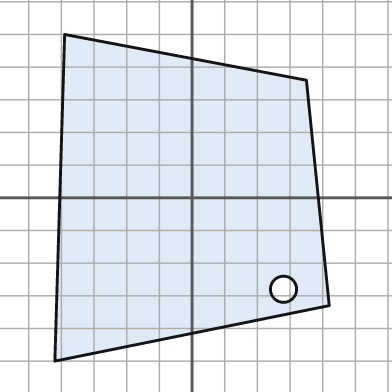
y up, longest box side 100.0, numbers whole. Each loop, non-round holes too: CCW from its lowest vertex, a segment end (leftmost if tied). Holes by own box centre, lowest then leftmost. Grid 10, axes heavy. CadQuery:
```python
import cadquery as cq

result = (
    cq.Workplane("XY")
    .moveTo(-42.0, -50.0)
    .lineTo(42.0, -33.0)
    .lineTo(35.0, 36.0)
    .lineTo(-39.0, 50.0)
    .close()
    .moveTo(28.0, -28.0)
    .circle(4.0)
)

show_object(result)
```